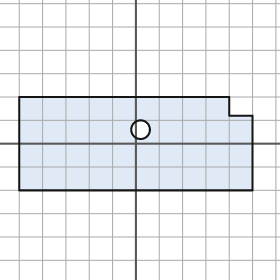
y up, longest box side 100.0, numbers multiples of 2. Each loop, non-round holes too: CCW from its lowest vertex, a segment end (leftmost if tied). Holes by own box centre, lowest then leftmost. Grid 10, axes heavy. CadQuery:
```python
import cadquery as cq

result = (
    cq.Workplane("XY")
    .moveTo(-50.0, -20.0)
    .lineTo(50.0, -20.0)
    .lineTo(50.0, 12.0)
    .lineTo(40.0, 12.0)
    .lineTo(40.0, 20.0)
    .lineTo(-50.0, 20.0)
    .close()
    .moveTo(2.0, 6.0)
    .circle(4.0)
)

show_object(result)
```